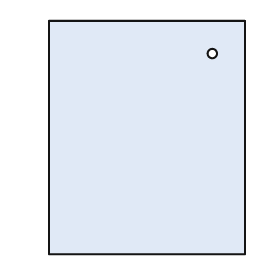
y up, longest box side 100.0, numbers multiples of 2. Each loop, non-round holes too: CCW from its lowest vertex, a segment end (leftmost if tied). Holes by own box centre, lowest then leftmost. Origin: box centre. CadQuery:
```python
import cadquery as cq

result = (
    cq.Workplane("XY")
    .moveTo(-42.0, -50.0)
    .lineTo(42.0, -50.0)
    .lineTo(42.0, 50.0)
    .lineTo(-42.0, 50.0)
    .close()
    .moveTo(28.0, 36.0)
    .circle(2.0)
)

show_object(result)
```